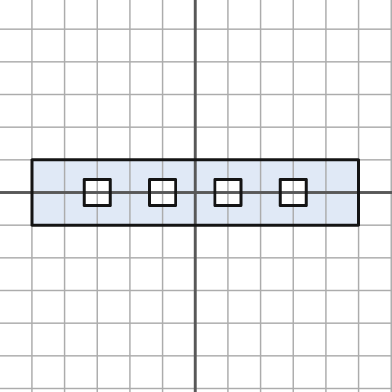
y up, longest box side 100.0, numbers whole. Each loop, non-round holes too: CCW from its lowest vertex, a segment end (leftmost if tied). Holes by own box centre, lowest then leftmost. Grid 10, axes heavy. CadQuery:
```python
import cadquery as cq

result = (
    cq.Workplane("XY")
    .moveTo(-50.0, -10.0)
    .lineTo(50.0, -10.0)
    .lineTo(50.0, 10.0)
    .lineTo(-50.0, 10.0)
    .close()
    .moveTo(-34.0, -4.0)
    .lineTo(-26.0, -4.0)
    .lineTo(-26.0, 4.0)
    .lineTo(-34.0, 4.0)
    .close()
    .moveTo(-14.0, -4.0)
    .lineTo(-6.0, -4.0)
    .lineTo(-6.0, 4.0)
    .lineTo(-14.0, 4.0)
    .close()
    .moveTo(6.0, -4.0)
    .lineTo(14.0, -4.0)
    .lineTo(14.0, 4.0)
    .lineTo(6.0, 4.0)
    .close()
    .moveTo(26.0, -4.0)
    .lineTo(34.0, -4.0)
    .lineTo(34.0, 4.0)
    .lineTo(26.0, 4.0)
    .close()
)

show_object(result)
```